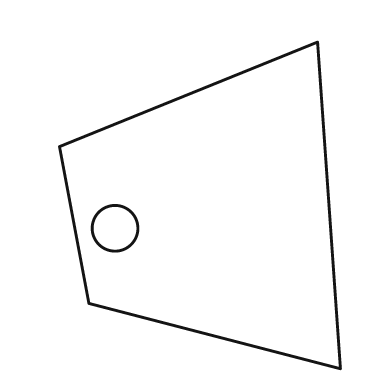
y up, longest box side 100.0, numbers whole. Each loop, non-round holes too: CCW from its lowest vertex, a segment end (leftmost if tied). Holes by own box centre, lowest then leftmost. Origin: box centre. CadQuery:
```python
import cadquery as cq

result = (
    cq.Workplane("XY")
    .moveTo(43.0, -50.0)
    .lineTo(36.0, 50.0)
    .lineTo(-43.0, 18.0)
    .lineTo(-34.0, -30.0)
    .close()
    .moveTo(-26.0, -7.0)
    .circle(7.0)
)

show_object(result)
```